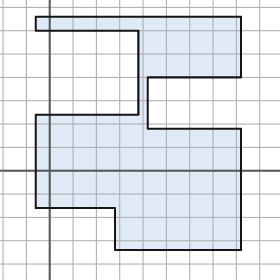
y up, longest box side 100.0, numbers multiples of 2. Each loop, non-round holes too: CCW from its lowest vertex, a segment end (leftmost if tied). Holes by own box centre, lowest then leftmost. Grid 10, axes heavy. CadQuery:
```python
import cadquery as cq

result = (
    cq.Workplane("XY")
    .moveTo(28.0, -34.0)
    .lineTo(82.0, -34.0)
    .lineTo(82.0, 18.0)
    .lineTo(42.0, 18.0)
    .lineTo(42.0, 40.0)
    .lineTo(82.0, 40.0)
    .lineTo(82.0, 66.0)
    .lineTo(-6.0, 66.0)
    .lineTo(-6.0, 60.0)
    .lineTo(38.0, 60.0)
    .lineTo(38.0, 24.0)
    .lineTo(-6.0, 24.0)
    .lineTo(-6.0, -16.0)
    .lineTo(28.0, -16.0)
    .close()
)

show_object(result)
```